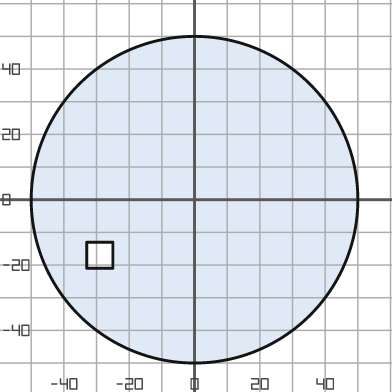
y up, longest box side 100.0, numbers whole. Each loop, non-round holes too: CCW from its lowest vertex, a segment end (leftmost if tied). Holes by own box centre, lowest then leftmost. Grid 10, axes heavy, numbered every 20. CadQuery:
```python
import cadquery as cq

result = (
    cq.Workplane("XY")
    .moveTo(0.0, 0.0)
    .circle(50.0)
    .moveTo(-33.0, -21.0)
    .lineTo(-25.0, -21.0)
    .lineTo(-25.0, -13.0)
    .lineTo(-33.0, -13.0)
    .close()
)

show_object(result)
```